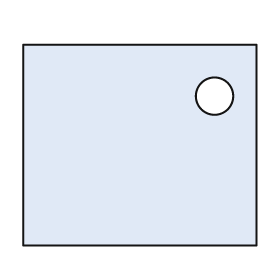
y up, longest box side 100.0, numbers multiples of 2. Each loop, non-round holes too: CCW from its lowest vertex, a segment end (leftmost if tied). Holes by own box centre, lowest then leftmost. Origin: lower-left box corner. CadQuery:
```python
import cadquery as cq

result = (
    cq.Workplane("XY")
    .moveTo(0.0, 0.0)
    .lineTo(100.0, 0.0)
    .lineTo(100.0, 86.0)
    .lineTo(0.0, 86.0)
    .close()
    .moveTo(82.0, 64.0)
    .circle(8.0)
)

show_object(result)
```